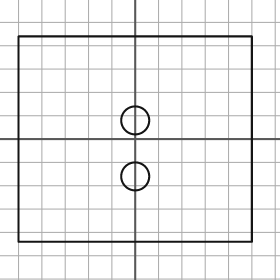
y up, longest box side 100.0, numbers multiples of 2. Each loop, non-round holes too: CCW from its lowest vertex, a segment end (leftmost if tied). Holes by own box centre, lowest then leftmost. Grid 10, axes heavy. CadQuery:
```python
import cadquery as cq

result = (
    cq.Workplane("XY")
    .moveTo(-50.0, -44.0)
    .lineTo(50.0, -44.0)
    .lineTo(50.0, 44.0)
    .lineTo(-50.0, 44.0)
    .close()
    .moveTo(0.0, -16.0)
    .circle(6.0)
    .moveTo(0.0, 8.0)
    .circle(6.0)
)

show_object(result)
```